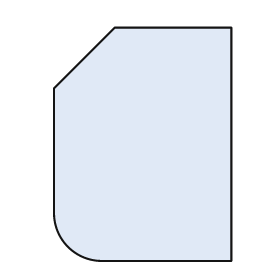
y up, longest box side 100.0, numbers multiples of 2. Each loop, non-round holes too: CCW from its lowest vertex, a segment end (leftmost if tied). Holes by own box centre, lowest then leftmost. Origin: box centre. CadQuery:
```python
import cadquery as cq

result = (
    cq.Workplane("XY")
    .moveTo(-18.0, -50.0)
    .lineTo(38.0, -50.0)
    .lineTo(38.0, 50.0)
    .lineTo(-12.0, 50.0)
    .lineTo(-38.0, 24.0)
    .lineTo(-38.0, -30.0)
    .threePointArc((-32.0, -44.0), (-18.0, -50.0))
    .close()
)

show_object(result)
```